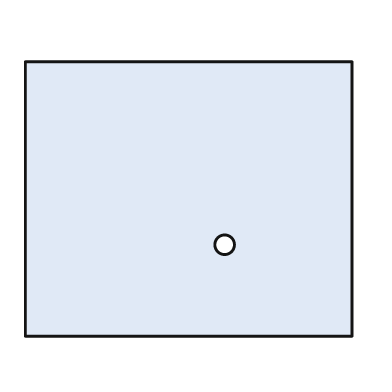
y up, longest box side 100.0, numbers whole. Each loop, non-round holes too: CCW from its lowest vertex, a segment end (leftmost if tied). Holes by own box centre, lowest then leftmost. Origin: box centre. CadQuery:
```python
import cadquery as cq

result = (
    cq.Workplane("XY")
    .moveTo(-50.0, -42.0)
    .lineTo(50.0, -42.0)
    .lineTo(50.0, 42.0)
    .lineTo(-50.0, 42.0)
    .close()
    .moveTo(11.0, -14.0)
    .circle(3.0)
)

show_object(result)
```